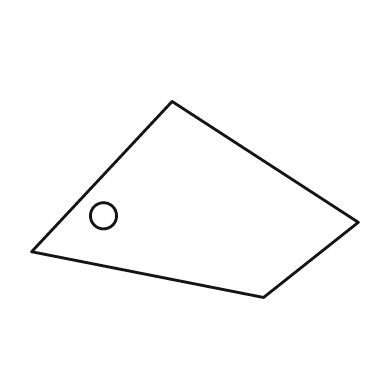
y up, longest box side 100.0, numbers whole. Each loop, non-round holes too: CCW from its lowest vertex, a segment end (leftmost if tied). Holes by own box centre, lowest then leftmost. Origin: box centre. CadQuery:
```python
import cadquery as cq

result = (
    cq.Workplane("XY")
    .moveTo(21.0, -30.0)
    .lineTo(50.0, -7.0)
    .lineTo(-7.0, 30.0)
    .lineTo(-50.0, -16.0)
    .close()
    .moveTo(-28.0, -5.0)
    .circle(4.0)
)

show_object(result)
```